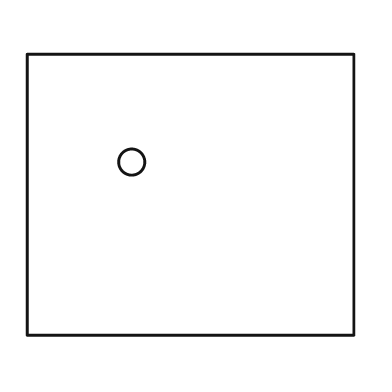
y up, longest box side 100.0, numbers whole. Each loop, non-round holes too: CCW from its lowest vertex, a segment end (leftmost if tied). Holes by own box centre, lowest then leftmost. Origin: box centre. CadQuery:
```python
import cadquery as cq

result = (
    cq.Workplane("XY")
    .moveTo(-50.0, -43.0)
    .lineTo(50.0, -43.0)
    .lineTo(50.0, 43.0)
    .lineTo(-50.0, 43.0)
    .close()
    .moveTo(-18.0, 10.0)
    .circle(4.0)
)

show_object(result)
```